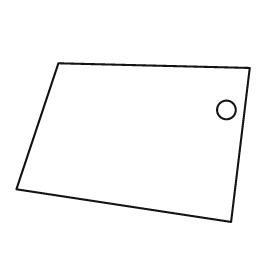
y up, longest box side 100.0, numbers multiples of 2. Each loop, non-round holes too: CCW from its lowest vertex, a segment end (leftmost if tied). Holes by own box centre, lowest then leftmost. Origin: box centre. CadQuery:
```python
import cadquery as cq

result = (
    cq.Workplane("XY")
    .moveTo(42.0, -34.0)
    .lineTo(50.0, 32.0)
    .lineTo(-32.0, 34.0)
    .lineTo(-50.0, -20.0)
    .close()
    .moveTo(40.0, 14.0)
    .circle(4.0)
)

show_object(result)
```